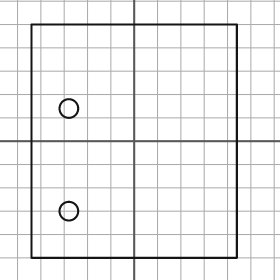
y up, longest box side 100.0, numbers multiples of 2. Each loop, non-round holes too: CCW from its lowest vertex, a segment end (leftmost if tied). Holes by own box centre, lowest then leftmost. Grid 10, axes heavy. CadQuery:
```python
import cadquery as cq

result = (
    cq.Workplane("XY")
    .moveTo(-44.0, -50.0)
    .lineTo(44.0, -50.0)
    .lineTo(44.0, 50.0)
    .lineTo(-44.0, 50.0)
    .close()
    .moveTo(-28.0, -30.0)
    .circle(4.0)
    .moveTo(-28.0, 14.0)
    .circle(4.0)
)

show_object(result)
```